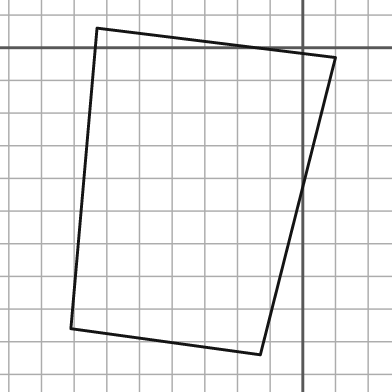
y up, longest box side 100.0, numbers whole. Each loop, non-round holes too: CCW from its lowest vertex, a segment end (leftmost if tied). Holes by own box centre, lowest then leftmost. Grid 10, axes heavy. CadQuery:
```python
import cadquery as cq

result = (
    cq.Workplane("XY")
    .moveTo(-13.0, -94.0)
    .lineTo(10.0, -3.0)
    .lineTo(-63.0, 6.0)
    .lineTo(-71.0, -86.0)
    .close()
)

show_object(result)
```